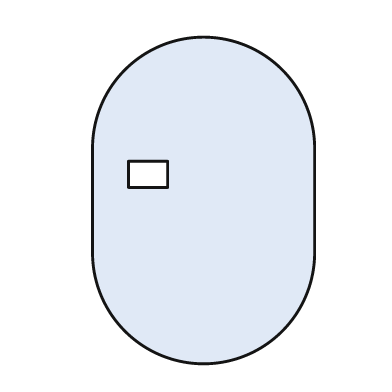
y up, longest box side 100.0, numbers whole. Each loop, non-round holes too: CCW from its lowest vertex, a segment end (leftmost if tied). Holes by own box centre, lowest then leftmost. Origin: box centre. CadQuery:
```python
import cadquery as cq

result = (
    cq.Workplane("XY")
    .moveTo(-34.0, -16.0)
    .threePointArc((0.0, -50.0), (34.0, -16.0))
    .lineTo(34.0, 16.0)
    .threePointArc((0.0, 50.0), (-34.0, 16.0))
    .close()
    .moveTo(-23.0, 4.0)
    .lineTo(-11.0, 4.0)
    .lineTo(-11.0, 12.0)
    .lineTo(-23.0, 12.0)
    .close()
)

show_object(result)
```